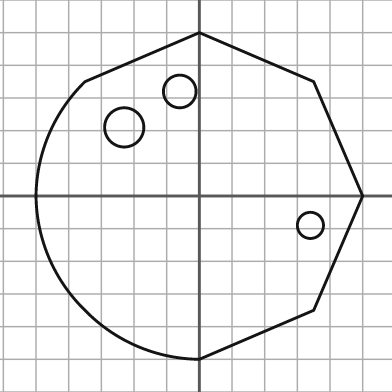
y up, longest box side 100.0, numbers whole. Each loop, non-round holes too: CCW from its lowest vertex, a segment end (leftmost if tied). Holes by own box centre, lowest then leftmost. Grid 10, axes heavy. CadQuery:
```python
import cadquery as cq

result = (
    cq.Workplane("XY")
    .moveTo(0.0, -50.0)
    .lineTo(35.0, -35.0)
    .lineTo(50.0, 0.0)
    .lineTo(35.0, 35.0)
    .lineTo(0.0, 50.0)
    .lineTo(-35.0, 35.0)
    .threePointArc((-46.0, 19.0), (-50.0, 0.0))
    .threePointArc((-46.0, -19.0), (-35.0, -35.0))
    .threePointArc((-19.0, -46.0), (0.0, -50.0))
    .close()
    .moveTo(34.0, -9.0)
    .circle(4.0)
    .moveTo(-23.0, 21.0)
    .circle(6.0)
    .moveTo(-6.0, 32.0)
    .circle(5.0)
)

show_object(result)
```